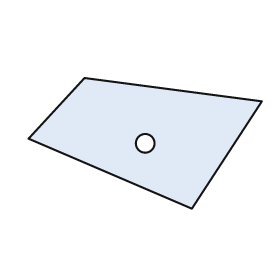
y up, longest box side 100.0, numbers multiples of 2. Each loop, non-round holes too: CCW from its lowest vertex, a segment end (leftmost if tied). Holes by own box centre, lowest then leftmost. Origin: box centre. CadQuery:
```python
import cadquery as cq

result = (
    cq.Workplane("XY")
    .moveTo(20.0, -28.0)
    .lineTo(50.0, 18.0)
    .lineTo(-26.0, 28.0)
    .lineTo(-50.0, 2.0)
    .close()
    .moveTo(0.0, 0.0)
    .circle(4.0)
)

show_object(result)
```